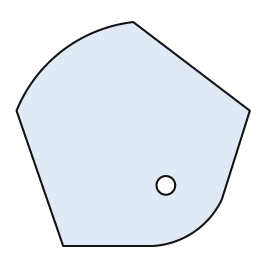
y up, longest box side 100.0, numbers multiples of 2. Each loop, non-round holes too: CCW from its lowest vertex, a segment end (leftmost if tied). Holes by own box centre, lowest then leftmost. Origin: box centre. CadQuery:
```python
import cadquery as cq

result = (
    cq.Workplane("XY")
    .moveTo(-30.0, -48.0)
    .lineTo(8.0, -48.0)
    .threePointArc((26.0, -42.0), (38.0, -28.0))
    .lineTo(50.0, 10.0)
    .lineTo(0.0, 48.0)
    .threePointArc((-30.0, 36.0), (-50.0, 10.0))
    .close()
    .moveTo(14.0, -22.0)
    .circle(4.0)
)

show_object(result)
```